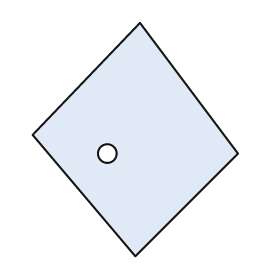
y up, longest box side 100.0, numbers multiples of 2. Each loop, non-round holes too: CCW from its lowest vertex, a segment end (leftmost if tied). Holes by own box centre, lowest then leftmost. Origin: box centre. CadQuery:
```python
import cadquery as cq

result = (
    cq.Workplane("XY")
    .moveTo(0.0, -50.0)
    .lineTo(44.0, -6.0)
    .lineTo(2.0, 50.0)
    .lineTo(-44.0, 2.0)
    .close()
    .moveTo(-12.0, -6.0)
    .circle(4.0)
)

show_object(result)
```